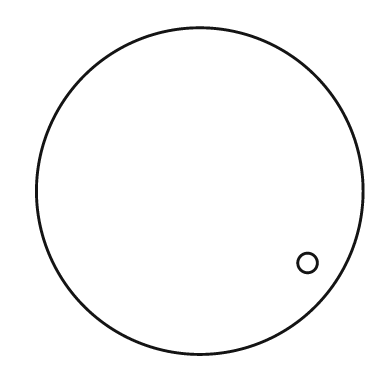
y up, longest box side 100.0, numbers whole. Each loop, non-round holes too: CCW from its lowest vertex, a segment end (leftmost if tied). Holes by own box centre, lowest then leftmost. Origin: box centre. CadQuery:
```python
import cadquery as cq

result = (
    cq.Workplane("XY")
    .moveTo(0.0, 0.0)
    .circle(50.0)
    .moveTo(33.0, -22.0)
    .circle(3.0)
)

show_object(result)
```